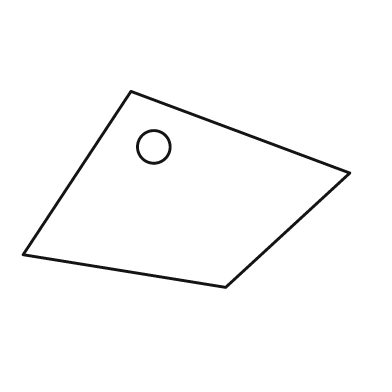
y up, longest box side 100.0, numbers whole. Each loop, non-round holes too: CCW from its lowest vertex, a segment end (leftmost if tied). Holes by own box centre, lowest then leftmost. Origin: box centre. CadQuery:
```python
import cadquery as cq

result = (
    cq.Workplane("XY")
    .moveTo(12.0, -30.0)
    .lineTo(50.0, 5.0)
    .lineTo(-17.0, 30.0)
    .lineTo(-50.0, -20.0)
    .close()
    .moveTo(-10.0, 13.0)
    .circle(5.0)
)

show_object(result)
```